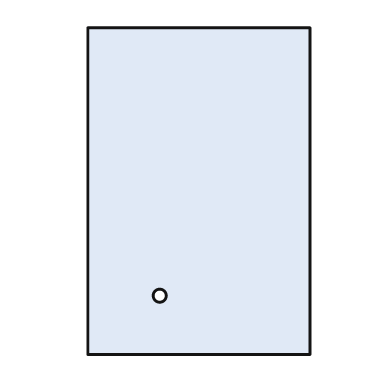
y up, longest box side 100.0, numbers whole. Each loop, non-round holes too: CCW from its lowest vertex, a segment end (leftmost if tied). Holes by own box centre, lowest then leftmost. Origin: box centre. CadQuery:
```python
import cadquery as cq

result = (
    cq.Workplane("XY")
    .moveTo(-34.0, -50.0)
    .lineTo(34.0, -50.0)
    .lineTo(34.0, 50.0)
    .lineTo(-34.0, 50.0)
    .close()
    .moveTo(-12.0, -32.0)
    .circle(2.0)
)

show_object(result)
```